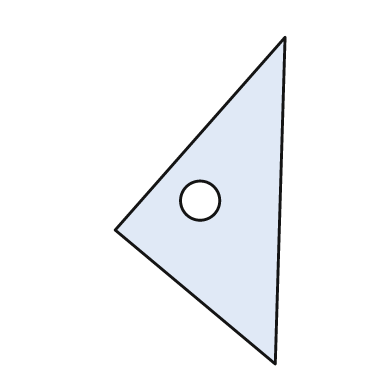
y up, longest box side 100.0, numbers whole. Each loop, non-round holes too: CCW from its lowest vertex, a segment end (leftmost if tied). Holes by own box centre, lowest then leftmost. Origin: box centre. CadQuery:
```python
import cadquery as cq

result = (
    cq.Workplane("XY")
    .moveTo(23.0, -50.0)
    .lineTo(26.0, 50.0)
    .lineTo(-26.0, -9.0)
    .close()
    .moveTo(0.0, 0.0)
    .circle(6.0)
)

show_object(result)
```